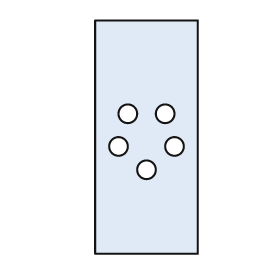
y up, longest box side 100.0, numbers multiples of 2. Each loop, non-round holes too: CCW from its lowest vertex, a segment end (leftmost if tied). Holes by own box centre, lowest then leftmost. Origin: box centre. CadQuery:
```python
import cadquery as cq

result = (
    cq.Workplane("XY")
    .moveTo(-22.0, -50.0)
    .lineTo(22.0, -50.0)
    .lineTo(22.0, 50.0)
    .lineTo(-22.0, 50.0)
    .close()
    .moveTo(0.0, -14.0)
    .circle(4.0)
    .moveTo(-12.0, -4.0)
    .circle(4.0)
    .moveTo(12.0, -4.0)
    .circle(4.0)
    .moveTo(-8.0, 10.0)
    .circle(4.0)
    .moveTo(8.0, 10.0)
    .circle(4.0)
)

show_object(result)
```